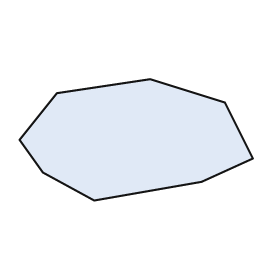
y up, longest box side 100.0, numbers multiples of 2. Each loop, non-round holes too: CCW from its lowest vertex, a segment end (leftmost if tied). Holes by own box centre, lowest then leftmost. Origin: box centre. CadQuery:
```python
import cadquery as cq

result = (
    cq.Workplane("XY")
    .moveTo(-18.0, -26.0)
    .lineTo(28.0, -18.0)
    .lineTo(50.0, -8.0)
    .lineTo(38.0, 16.0)
    .lineTo(6.0, 26.0)
    .lineTo(-34.0, 20.0)
    .lineTo(-50.0, 0.0)
    .lineTo(-40.0, -14.0)
    .close()
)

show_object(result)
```